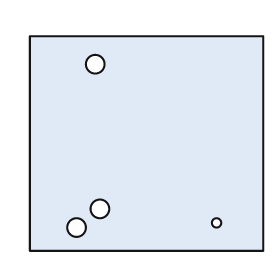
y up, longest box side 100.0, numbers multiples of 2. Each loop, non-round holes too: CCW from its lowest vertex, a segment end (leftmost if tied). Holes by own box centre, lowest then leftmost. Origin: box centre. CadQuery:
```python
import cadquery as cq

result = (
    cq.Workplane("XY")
    .moveTo(-50.0, -46.0)
    .lineTo(50.0, -46.0)
    .lineTo(50.0, 46.0)
    .lineTo(-50.0, 46.0)
    .close()
    .moveTo(-30.0, -36.0)
    .circle(4.0)
    .moveTo(30.0, -34.0)
    .circle(2.0)
    .moveTo(-20.0, -28.0)
    .circle(4.0)
    .moveTo(-22.0, 34.0)
    .circle(4.0)
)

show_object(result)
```